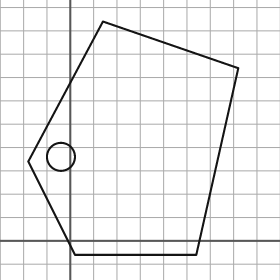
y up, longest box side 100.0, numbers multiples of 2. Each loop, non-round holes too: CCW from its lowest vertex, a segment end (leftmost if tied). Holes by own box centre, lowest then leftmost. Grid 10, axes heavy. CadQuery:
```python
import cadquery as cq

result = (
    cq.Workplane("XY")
    .moveTo(2.0, -6.0)
    .lineTo(54.0, -6.0)
    .lineTo(72.0, 74.0)
    .lineTo(14.0, 94.0)
    .lineTo(-18.0, 34.0)
    .close()
    .moveTo(-4.0, 36.0)
    .circle(6.0)
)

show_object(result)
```